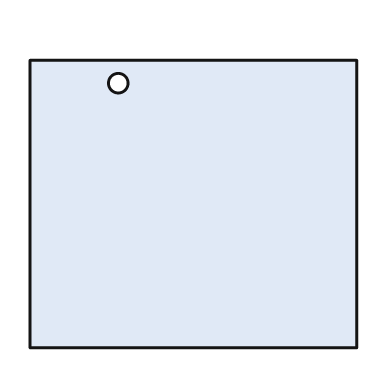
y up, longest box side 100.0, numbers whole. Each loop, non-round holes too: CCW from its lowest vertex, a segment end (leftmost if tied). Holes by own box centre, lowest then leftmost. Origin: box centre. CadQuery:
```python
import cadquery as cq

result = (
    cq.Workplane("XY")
    .moveTo(-50.0, -44.0)
    .lineTo(50.0, -44.0)
    .lineTo(50.0, 44.0)
    .lineTo(-50.0, 44.0)
    .close()
    .moveTo(-23.0, 37.0)
    .circle(3.0)
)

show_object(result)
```